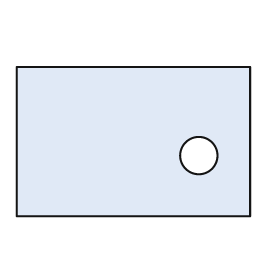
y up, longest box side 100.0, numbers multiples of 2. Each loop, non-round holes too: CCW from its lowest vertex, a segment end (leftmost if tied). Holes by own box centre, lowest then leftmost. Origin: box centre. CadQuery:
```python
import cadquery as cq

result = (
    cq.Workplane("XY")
    .moveTo(-50.0, -32.0)
    .lineTo(50.0, -32.0)
    .lineTo(50.0, 32.0)
    .lineTo(-50.0, 32.0)
    .close()
    .moveTo(28.0, -6.0)
    .circle(8.0)
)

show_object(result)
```